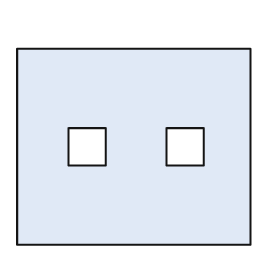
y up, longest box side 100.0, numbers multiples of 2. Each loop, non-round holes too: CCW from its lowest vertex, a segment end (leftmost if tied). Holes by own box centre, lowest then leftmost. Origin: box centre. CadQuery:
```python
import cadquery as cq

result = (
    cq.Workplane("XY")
    .moveTo(-50.0, -42.0)
    .lineTo(50.0, -42.0)
    .lineTo(50.0, 42.0)
    .lineTo(-50.0, 42.0)
    .close()
    .moveTo(-28.0, -8.0)
    .lineTo(-12.0, -8.0)
    .lineTo(-12.0, 8.0)
    .lineTo(-28.0, 8.0)
    .close()
    .moveTo(14.0, -8.0)
    .lineTo(30.0, -8.0)
    .lineTo(30.0, 8.0)
    .lineTo(14.0, 8.0)
    .close()
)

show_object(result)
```